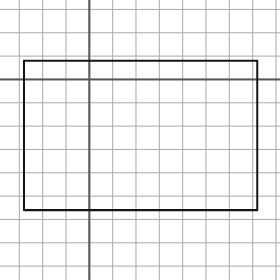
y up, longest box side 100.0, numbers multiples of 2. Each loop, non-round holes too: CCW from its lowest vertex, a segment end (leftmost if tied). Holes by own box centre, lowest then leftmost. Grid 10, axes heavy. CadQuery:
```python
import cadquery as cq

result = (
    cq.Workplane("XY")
    .moveTo(-28.0, -56.0)
    .lineTo(72.0, -56.0)
    .lineTo(72.0, 8.0)
    .lineTo(-28.0, 8.0)
    .close()
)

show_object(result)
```